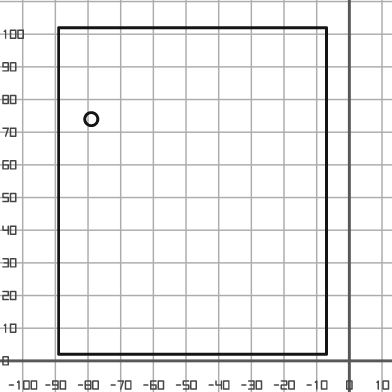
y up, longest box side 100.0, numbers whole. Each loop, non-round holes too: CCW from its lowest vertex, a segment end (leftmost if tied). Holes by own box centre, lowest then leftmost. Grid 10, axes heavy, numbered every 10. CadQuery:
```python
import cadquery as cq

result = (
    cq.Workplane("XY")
    .moveTo(-89.0, 2.0)
    .lineTo(-7.0, 2.0)
    .lineTo(-7.0, 102.0)
    .lineTo(-89.0, 102.0)
    .close()
    .moveTo(-79.0, 74.0)
    .circle(2.0)
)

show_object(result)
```